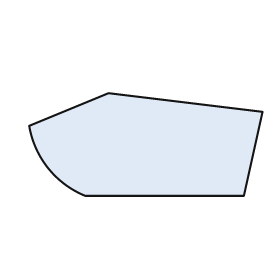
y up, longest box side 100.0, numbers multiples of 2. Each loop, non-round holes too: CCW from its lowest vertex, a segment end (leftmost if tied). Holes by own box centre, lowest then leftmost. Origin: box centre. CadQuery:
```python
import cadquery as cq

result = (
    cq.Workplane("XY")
    .moveTo(-26.0, -22.0)
    .lineTo(42.0, -22.0)
    .lineTo(50.0, 14.0)
    .lineTo(-16.0, 22.0)
    .lineTo(-50.0, 8.0)
    .threePointArc((-42.0, -10.0), (-26.0, -22.0))
    .close()
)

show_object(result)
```